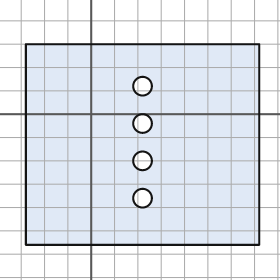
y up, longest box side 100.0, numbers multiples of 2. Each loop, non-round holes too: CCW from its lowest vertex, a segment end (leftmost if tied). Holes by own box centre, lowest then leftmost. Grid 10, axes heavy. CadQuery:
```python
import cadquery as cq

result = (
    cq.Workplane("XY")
    .moveTo(-28.0, -56.0)
    .lineTo(72.0, -56.0)
    .lineTo(72.0, 30.0)
    .lineTo(-28.0, 30.0)
    .close()
    .moveTo(22.0, -36.0)
    .circle(4.0)
    .moveTo(22.0, -20.0)
    .circle(4.0)
    .moveTo(22.0, -4.0)
    .circle(4.0)
    .moveTo(22.0, 12.0)
    .circle(4.0)
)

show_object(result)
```